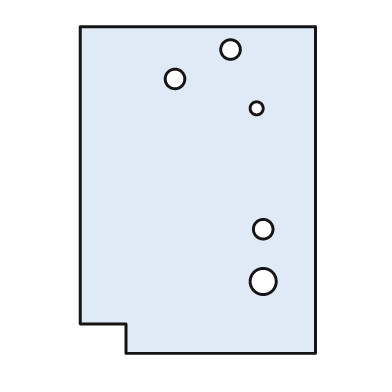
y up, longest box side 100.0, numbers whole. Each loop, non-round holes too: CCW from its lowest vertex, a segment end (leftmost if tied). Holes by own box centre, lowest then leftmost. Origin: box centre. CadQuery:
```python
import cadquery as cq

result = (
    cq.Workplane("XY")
    .moveTo(-22.0, -50.0)
    .lineTo(36.0, -50.0)
    .lineTo(36.0, 50.0)
    .lineTo(-36.0, 50.0)
    .lineTo(-36.0, -41.0)
    .lineTo(-22.0, -41.0)
    .close()
    .moveTo(20.0, -28.0)
    .circle(4.0)
    .moveTo(20.0, -12.0)
    .circle(3.0)
    .moveTo(18.0, 25.0)
    .circle(2.0)
    .moveTo(-7.0, 34.0)
    .circle(3.0)
    .moveTo(10.0, 43.0)
    .circle(3.0)
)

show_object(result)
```